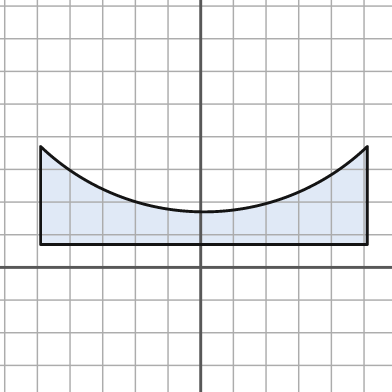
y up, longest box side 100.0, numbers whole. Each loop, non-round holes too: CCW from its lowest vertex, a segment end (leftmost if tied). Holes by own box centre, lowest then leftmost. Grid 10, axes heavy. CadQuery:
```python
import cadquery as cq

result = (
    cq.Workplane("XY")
    .moveTo(-49.0, 7.0)
    .lineTo(51.0, 7.0)
    .lineTo(51.0, 37.0)
    .threePointArc((1.0, 17.0), (-49.0, 37.0))
    .close()
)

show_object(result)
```